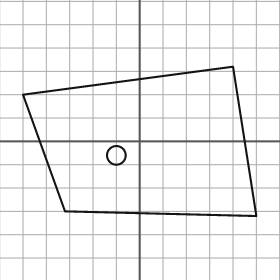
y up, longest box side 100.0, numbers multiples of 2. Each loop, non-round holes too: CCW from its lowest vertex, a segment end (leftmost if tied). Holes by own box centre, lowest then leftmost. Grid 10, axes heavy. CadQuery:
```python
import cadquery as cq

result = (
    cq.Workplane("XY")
    .moveTo(50.0, -32.0)
    .lineTo(40.0, 32.0)
    .lineTo(-50.0, 20.0)
    .lineTo(-32.0, -30.0)
    .close()
    .moveTo(-10.0, -6.0)
    .circle(4.0)
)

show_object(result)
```